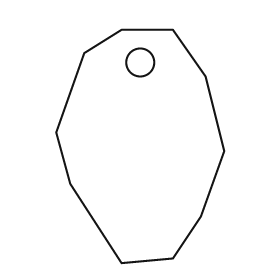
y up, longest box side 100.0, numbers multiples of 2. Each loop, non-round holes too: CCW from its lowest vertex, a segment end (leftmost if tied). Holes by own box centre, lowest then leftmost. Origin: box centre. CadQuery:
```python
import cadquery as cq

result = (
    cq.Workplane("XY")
    .moveTo(-8.0, -50.0)
    .lineTo(14.0, -48.0)
    .lineTo(26.0, -30.0)
    .lineTo(36.0, -2.0)
    .lineTo(28.0, 30.0)
    .lineTo(14.0, 50.0)
    .lineTo(-8.0, 50.0)
    .lineTo(-24.0, 40.0)
    .lineTo(-36.0, 6.0)
    .lineTo(-30.0, -16.0)
    .close()
    .moveTo(0.0, 36.0)
    .circle(6.0)
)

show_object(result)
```